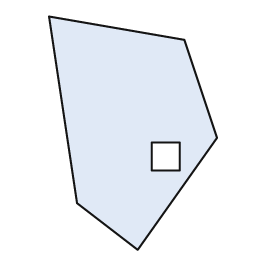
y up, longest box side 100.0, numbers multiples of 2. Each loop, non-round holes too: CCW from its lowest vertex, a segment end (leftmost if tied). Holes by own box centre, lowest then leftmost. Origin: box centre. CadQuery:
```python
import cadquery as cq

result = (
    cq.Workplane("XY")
    .moveTo(2.0, -50.0)
    .lineTo(36.0, -2.0)
    .lineTo(22.0, 40.0)
    .lineTo(-36.0, 50.0)
    .lineTo(-24.0, -30.0)
    .close()
    .moveTo(8.0, -16.0)
    .lineTo(20.0, -16.0)
    .lineTo(20.0, -4.0)
    .lineTo(8.0, -4.0)
    .close()
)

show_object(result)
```